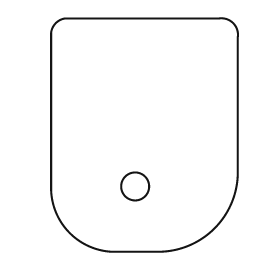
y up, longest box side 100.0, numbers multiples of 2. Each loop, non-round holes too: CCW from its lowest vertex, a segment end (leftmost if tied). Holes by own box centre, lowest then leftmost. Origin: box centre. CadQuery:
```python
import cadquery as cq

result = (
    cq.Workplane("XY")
    .moveTo(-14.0, -50.0)
    .lineTo(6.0, -50.0)
    .threePointArc((30.0, -40.0), (40.0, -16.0))
    .lineTo(40.0, 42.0)
    .threePointArc((38.0, 48.0), (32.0, 50.0))
    .lineTo(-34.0, 50.0)
    .threePointArc((-38.0, 48.0), (-40.0, 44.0))
    .lineTo(-40.0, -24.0)
    .threePointArc((-32.0, -42.0), (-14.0, -50.0))
    .close()
    .moveTo(-4.0, -22.0)
    .circle(6.0)
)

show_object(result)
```